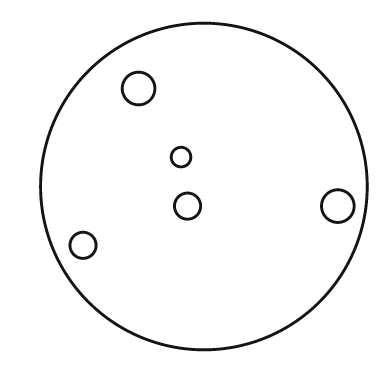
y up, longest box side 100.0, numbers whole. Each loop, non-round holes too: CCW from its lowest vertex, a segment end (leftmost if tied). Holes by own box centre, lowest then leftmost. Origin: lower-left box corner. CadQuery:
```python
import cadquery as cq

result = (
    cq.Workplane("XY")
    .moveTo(50.0, 50.0)
    .circle(50.0)
    .moveTo(13.0, 32.0)
    .circle(4.0)
    .moveTo(45.0, 44.0)
    .circle(4.0)
    .moveTo(91.0, 44.0)
    .circle(5.0)
    .moveTo(43.0, 59.0)
    .circle(3.0)
    .moveTo(30.0, 80.0)
    .circle(5.0)
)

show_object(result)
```